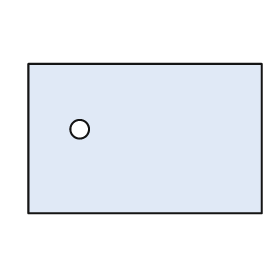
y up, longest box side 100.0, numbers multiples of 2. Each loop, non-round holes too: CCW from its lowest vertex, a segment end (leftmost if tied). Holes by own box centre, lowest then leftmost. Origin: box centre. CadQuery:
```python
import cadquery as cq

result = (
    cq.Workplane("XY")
    .moveTo(-50.0, -32.0)
    .lineTo(50.0, -32.0)
    .lineTo(50.0, 32.0)
    .lineTo(-50.0, 32.0)
    .close()
    .moveTo(-28.0, 4.0)
    .circle(4.0)
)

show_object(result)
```